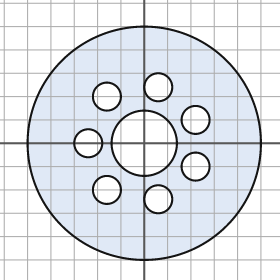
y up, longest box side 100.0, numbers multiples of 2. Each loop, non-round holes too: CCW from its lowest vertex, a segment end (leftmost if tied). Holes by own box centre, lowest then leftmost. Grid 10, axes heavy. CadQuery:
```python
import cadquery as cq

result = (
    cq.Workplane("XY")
    .moveTo(0.0, 0.0)
    .circle(50.0)
    .moveTo(6.0, -24.0)
    .circle(6.0)
    .moveTo(-16.0, -20.0)
    .circle(6.0)
    .moveTo(22.0, -10.0)
    .circle(6.0)
    .moveTo(-24.0, 0.0)
    .circle(6.0)
    .moveTo(0.0, 0.0)
    .circle(14.0)
    .moveTo(22.0, 10.0)
    .circle(6.0)
    .moveTo(-16.0, 20.0)
    .circle(6.0)
    .moveTo(6.0, 24.0)
    .circle(6.0)
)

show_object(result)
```